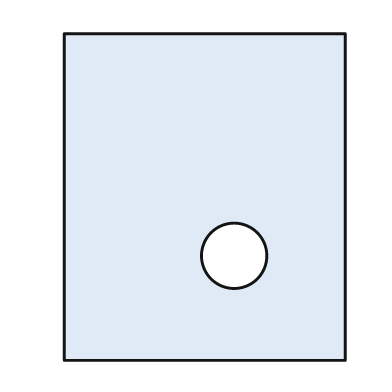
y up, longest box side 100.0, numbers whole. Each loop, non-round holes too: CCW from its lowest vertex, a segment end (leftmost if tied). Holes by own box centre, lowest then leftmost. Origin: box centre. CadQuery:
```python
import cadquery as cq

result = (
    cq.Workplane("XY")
    .moveTo(-43.0, -50.0)
    .lineTo(43.0, -50.0)
    .lineTo(43.0, 50.0)
    .lineTo(-43.0, 50.0)
    .close()
    .moveTo(9.0, -18.0)
    .circle(10.0)
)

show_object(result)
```